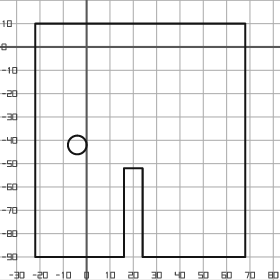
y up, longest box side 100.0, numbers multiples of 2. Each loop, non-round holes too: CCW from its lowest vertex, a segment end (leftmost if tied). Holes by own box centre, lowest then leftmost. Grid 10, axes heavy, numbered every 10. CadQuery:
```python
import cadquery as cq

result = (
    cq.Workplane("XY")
    .moveTo(-22.0, -90.0)
    .lineTo(16.0, -90.0)
    .lineTo(16.0, -52.0)
    .lineTo(24.0, -52.0)
    .lineTo(24.0, -90.0)
    .lineTo(68.0, -90.0)
    .lineTo(68.0, 10.0)
    .lineTo(-22.0, 10.0)
    .close()
    .moveTo(-4.0, -42.0)
    .circle(4.0)
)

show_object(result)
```